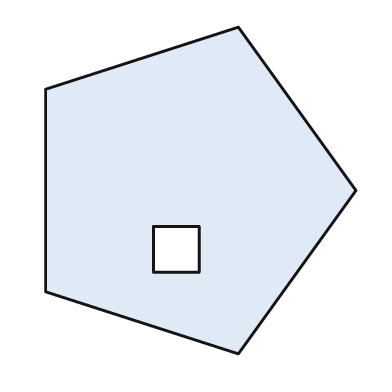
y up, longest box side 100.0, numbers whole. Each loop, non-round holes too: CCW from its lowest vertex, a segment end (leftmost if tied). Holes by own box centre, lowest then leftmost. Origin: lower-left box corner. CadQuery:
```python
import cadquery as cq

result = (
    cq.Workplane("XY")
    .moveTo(59.0, 0.0)
    .lineTo(95.0, 50.0)
    .lineTo(59.0, 100.0)
    .lineTo(0.0, 81.0)
    .lineTo(0.0, 19.0)
    .close()
    .moveTo(33.0, 25.0)
    .lineTo(47.0, 25.0)
    .lineTo(47.0, 39.0)
    .lineTo(33.0, 39.0)
    .close()
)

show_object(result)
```